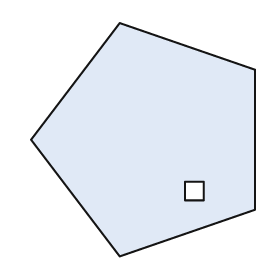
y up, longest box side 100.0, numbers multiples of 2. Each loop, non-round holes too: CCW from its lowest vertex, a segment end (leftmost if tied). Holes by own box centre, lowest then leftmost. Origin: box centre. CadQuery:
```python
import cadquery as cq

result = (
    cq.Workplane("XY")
    .moveTo(-10.0, -50.0)
    .lineTo(48.0, -30.0)
    .lineTo(48.0, 30.0)
    .lineTo(-10.0, 50.0)
    .lineTo(-48.0, 0.0)
    .close()
    .moveTo(18.0, -26.0)
    .lineTo(26.0, -26.0)
    .lineTo(26.0, -18.0)
    .lineTo(18.0, -18.0)
    .close()
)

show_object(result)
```